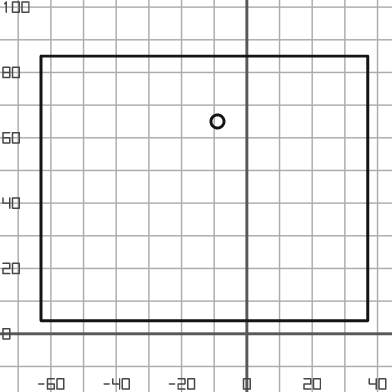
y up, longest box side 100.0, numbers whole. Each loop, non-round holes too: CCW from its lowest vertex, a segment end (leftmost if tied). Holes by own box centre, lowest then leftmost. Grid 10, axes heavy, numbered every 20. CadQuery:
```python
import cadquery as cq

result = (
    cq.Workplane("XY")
    .moveTo(-63.0, 4.0)
    .lineTo(37.0, 4.0)
    .lineTo(37.0, 85.0)
    .lineTo(-63.0, 85.0)
    .close()
    .moveTo(-9.0, 65.0)
    .circle(2.0)
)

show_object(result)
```